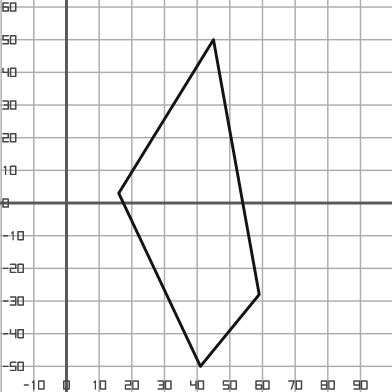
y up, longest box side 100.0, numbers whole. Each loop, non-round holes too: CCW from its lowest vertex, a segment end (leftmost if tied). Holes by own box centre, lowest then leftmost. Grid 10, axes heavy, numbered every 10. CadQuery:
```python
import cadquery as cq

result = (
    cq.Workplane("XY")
    .moveTo(41.0, -50.0)
    .lineTo(59.0, -28.0)
    .lineTo(45.0, 50.0)
    .lineTo(16.0, 3.0)
    .close()
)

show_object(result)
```